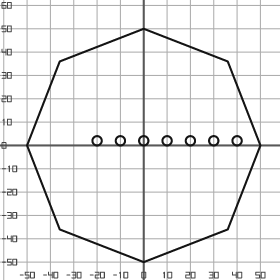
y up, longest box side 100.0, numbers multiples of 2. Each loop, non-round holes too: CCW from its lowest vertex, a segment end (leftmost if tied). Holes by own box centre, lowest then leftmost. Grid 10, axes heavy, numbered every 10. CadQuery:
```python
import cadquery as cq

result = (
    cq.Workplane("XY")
    .moveTo(0.0, -50.0)
    .lineTo(36.0, -36.0)
    .lineTo(50.0, 0.0)
    .lineTo(36.0, 36.0)
    .lineTo(0.0, 50.0)
    .lineTo(-36.0, 36.0)
    .lineTo(-50.0, 0.0)
    .lineTo(-36.0, -36.0)
    .close()
    .moveTo(-20.0, 2.0)
    .circle(2.0)
    .moveTo(-10.0, 2.0)
    .circle(2.0)
    .moveTo(0.0, 2.0)
    .circle(2.0)
    .moveTo(10.0, 2.0)
    .circle(2.0)
    .moveTo(20.0, 2.0)
    .circle(2.0)
    .moveTo(30.0, 2.0)
    .circle(2.0)
    .moveTo(40.0, 2.0)
    .circle(2.0)
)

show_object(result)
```